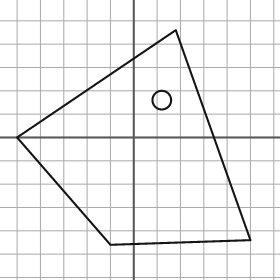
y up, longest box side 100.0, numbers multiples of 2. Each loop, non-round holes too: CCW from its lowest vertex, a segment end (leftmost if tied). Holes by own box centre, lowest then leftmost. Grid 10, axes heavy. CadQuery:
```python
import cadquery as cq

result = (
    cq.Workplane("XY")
    .moveTo(-10.0, -46.0)
    .lineTo(50.0, -44.0)
    .lineTo(18.0, 46.0)
    .lineTo(-50.0, 0.0)
    .close()
    .moveTo(12.0, 16.0)
    .circle(4.0)
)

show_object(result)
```